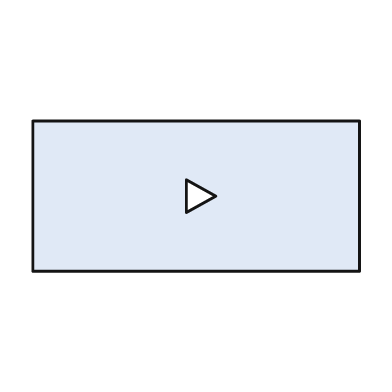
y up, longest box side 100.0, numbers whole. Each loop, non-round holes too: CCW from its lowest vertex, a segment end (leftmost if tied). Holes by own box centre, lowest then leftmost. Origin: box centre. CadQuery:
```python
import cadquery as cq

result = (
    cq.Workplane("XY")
    .moveTo(-50.0, -23.0)
    .lineTo(50.0, -23.0)
    .lineTo(50.0, 23.0)
    .lineTo(-50.0, 23.0)
    .close()
    .moveTo(-3.0, -5.0)
    .lineTo(6.0, 0.0)
    .lineTo(-3.0, 5.0)
    .close()
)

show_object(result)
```